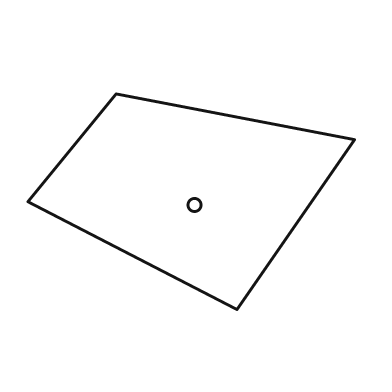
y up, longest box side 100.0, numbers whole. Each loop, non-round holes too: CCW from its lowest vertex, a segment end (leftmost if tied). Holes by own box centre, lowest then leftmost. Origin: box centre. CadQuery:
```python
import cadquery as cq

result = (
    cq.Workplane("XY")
    .moveTo(14.0, -33.0)
    .lineTo(50.0, 19.0)
    .lineTo(-23.0, 33.0)
    .lineTo(-50.0, 0.0)
    .close()
    .moveTo(1.0, -1.0)
    .circle(2.0)
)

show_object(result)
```